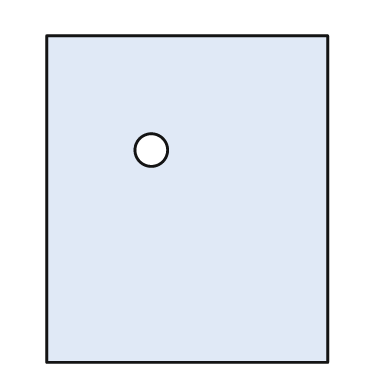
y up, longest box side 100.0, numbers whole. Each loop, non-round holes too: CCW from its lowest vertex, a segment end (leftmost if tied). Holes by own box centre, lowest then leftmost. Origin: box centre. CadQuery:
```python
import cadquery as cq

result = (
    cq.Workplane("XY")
    .moveTo(-43.0, -50.0)
    .lineTo(43.0, -50.0)
    .lineTo(43.0, 50.0)
    .lineTo(-43.0, 50.0)
    .close()
    .moveTo(-11.0, 15.0)
    .circle(5.0)
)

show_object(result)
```